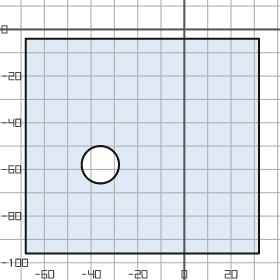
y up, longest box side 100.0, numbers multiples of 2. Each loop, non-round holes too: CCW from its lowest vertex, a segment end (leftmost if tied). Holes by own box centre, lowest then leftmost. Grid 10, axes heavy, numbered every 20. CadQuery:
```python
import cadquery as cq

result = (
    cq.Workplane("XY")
    .moveTo(-68.0, -96.0)
    .lineTo(32.0, -96.0)
    .lineTo(32.0, -4.0)
    .lineTo(-68.0, -4.0)
    .close()
    .moveTo(-36.0, -58.0)
    .circle(8.0)
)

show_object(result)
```